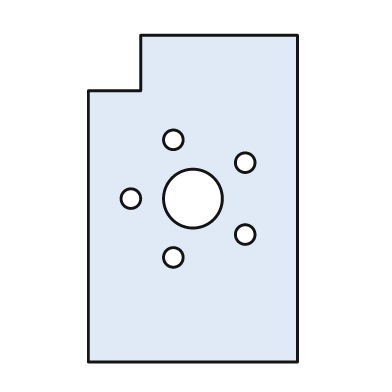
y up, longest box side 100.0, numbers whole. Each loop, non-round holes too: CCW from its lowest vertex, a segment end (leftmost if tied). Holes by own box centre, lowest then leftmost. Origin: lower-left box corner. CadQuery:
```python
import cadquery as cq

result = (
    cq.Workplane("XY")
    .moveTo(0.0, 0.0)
    .lineTo(64.0, 0.0)
    .lineTo(64.0, 100.0)
    .lineTo(16.0, 100.0)
    .lineTo(16.0, 83.0)
    .lineTo(0.0, 83.0)
    .close()
    .moveTo(26.0, 32.0)
    .circle(3.0)
    .moveTo(48.0, 39.0)
    .circle(3.0)
    .moveTo(13.0, 50.0)
    .circle(3.0)
    .moveTo(32.0, 50.0)
    .circle(9.0)
    .moveTo(48.0, 61.0)
    .circle(3.0)
    .moveTo(26.0, 68.0)
    .circle(3.0)
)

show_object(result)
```